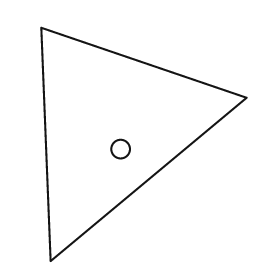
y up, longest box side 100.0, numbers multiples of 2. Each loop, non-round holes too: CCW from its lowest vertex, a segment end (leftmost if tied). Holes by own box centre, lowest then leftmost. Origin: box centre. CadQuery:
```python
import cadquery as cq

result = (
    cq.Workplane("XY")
    .moveTo(-40.0, -50.0)
    .lineTo(44.0, 20.0)
    .lineTo(-44.0, 50.0)
    .close()
    .moveTo(-10.0, -2.0)
    .circle(4.0)
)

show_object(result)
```